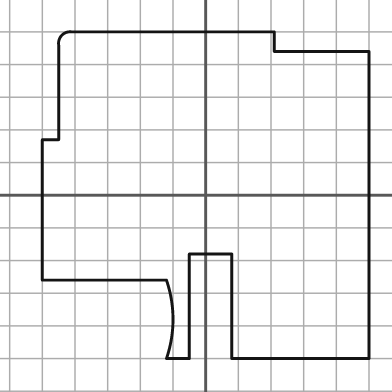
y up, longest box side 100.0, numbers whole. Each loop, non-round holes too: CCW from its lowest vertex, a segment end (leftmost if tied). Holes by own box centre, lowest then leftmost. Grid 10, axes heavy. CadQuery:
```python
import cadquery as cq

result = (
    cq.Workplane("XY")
    .moveTo(-12.0, -50.0)
    .lineTo(-5.0, -50.0)
    .lineTo(-5.0, -18.0)
    .lineTo(8.0, -18.0)
    .lineTo(8.0, -50.0)
    .lineTo(50.0, -50.0)
    .lineTo(50.0, 44.0)
    .lineTo(21.0, 44.0)
    .lineTo(21.0, 50.0)
    .lineTo(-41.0, 50.0)
    .threePointArc((-44.0, 49.0), (-45.0, 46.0))
    .lineTo(-45.0, 17.0)
    .lineTo(-50.0, 17.0)
    .lineTo(-50.0, -26.0)
    .lineTo(-12.0, -26.0)
    .threePointArc((-10.0, -38.0), (-12.0, -50.0))
    .close()
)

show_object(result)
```